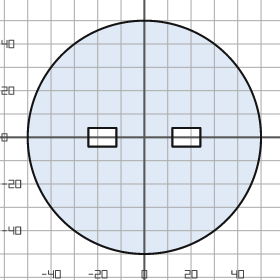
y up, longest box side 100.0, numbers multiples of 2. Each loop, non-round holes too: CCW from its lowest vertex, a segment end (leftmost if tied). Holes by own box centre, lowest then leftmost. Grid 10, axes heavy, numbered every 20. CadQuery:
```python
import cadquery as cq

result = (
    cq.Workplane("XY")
    .moveTo(0.0, 0.0)
    .circle(50.0)
    .moveTo(-24.0, -4.0)
    .lineTo(-12.0, -4.0)
    .lineTo(-12.0, 4.0)
    .lineTo(-24.0, 4.0)
    .close()
    .moveTo(12.0, -4.0)
    .lineTo(24.0, -4.0)
    .lineTo(24.0, 4.0)
    .lineTo(12.0, 4.0)
    .close()
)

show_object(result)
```